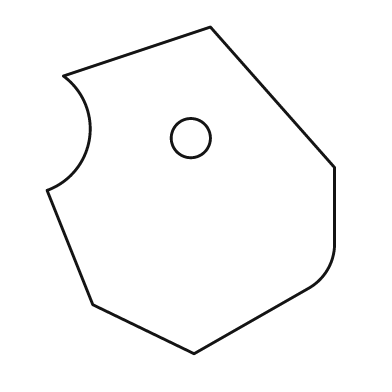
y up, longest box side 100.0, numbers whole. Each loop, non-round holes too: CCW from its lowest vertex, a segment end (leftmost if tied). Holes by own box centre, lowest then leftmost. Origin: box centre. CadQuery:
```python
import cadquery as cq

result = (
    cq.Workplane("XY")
    .moveTo(1.0, -50.0)
    .lineTo(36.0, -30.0)
    .threePointArc((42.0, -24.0), (44.0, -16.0))
    .lineTo(44.0, 7.0)
    .lineTo(6.0, 50.0)
    .lineTo(-39.0, 35.0)
    .threePointArc((-31.0, 16.0), (-44.0, 0.0))
    .lineTo(-30.0, -35.0)
    .close()
    .moveTo(0.0, 16.0)
    .circle(6.0)
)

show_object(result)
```